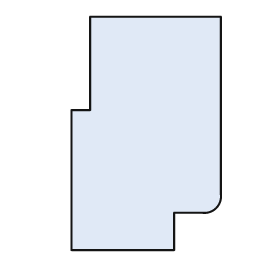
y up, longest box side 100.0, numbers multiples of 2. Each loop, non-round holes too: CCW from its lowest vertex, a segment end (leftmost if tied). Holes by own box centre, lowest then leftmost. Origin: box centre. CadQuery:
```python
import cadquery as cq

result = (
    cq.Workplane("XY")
    .moveTo(-32.0, -50.0)
    .lineTo(12.0, -50.0)
    .lineTo(12.0, -34.0)
    .lineTo(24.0, -34.0)
    .threePointArc((30.0, -32.0), (32.0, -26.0))
    .lineTo(32.0, 50.0)
    .lineTo(-24.0, 50.0)
    .lineTo(-24.0, 10.0)
    .lineTo(-32.0, 10.0)
    .close()
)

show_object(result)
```